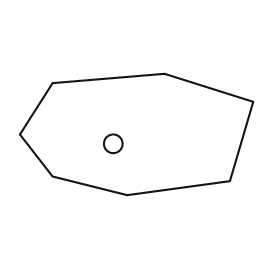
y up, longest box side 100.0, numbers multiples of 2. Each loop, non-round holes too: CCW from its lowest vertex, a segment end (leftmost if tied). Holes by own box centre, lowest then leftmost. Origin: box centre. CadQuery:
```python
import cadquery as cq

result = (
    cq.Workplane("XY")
    .moveTo(-4.0, -26.0)
    .lineTo(40.0, -20.0)
    .lineTo(50.0, 14.0)
    .lineTo(12.0, 26.0)
    .lineTo(-36.0, 22.0)
    .lineTo(-50.0, 0.0)
    .lineTo(-36.0, -18.0)
    .close()
    .moveTo(-10.0, -4.0)
    .circle(4.0)
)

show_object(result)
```